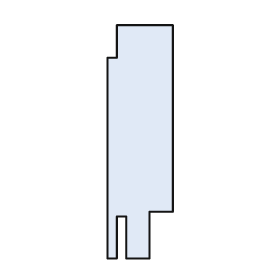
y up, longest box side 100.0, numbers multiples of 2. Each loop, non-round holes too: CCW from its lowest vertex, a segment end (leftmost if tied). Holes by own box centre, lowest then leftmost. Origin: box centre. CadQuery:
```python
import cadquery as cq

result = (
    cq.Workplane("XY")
    .moveTo(-14.0, -50.0)
    .lineTo(-10.0, -50.0)
    .lineTo(-10.0, -32.0)
    .lineTo(-6.0, -32.0)
    .lineTo(-6.0, -50.0)
    .lineTo(4.0, -50.0)
    .lineTo(4.0, -30.0)
    .lineTo(14.0, -30.0)
    .lineTo(14.0, 50.0)
    .lineTo(-10.0, 50.0)
    .lineTo(-10.0, 36.0)
    .lineTo(-14.0, 36.0)
    .close()
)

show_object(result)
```